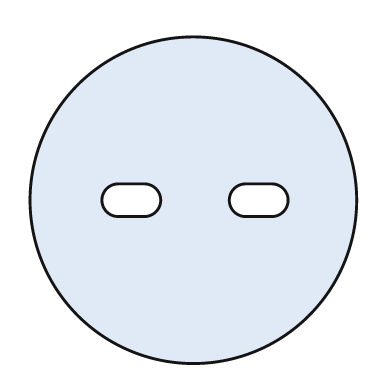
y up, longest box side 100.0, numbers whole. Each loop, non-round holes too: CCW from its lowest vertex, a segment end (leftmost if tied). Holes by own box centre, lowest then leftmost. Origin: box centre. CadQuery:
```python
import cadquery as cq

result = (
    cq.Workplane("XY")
    .moveTo(0.0, 0.0)
    .circle(50.0)
    .moveTo(-23.0, -5.0)
    .lineTo(-15.0, -5.0)
    .threePointArc((-10.0, 0.0), (-15.0, 5.0))
    .lineTo(-23.0, 5.0)
    .threePointArc((-28.0, 0.0), (-23.0, -5.0))
    .close()
    .moveTo(16.0, -5.0)
    .lineTo(24.0, -5.0)
    .threePointArc((29.0, 0.0), (24.0, 5.0))
    .lineTo(16.0, 5.0)
    .threePointArc((11.0, 0.0), (16.0, -5.0))
    .close()
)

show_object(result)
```